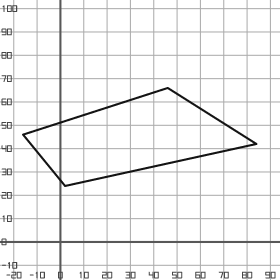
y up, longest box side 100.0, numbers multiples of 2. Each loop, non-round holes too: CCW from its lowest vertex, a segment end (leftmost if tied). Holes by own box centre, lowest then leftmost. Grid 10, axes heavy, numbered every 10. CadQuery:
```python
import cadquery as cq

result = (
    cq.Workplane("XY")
    .moveTo(2.0, 24.0)
    .lineTo(84.0, 42.0)
    .lineTo(46.0, 66.0)
    .lineTo(-16.0, 46.0)
    .close()
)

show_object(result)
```